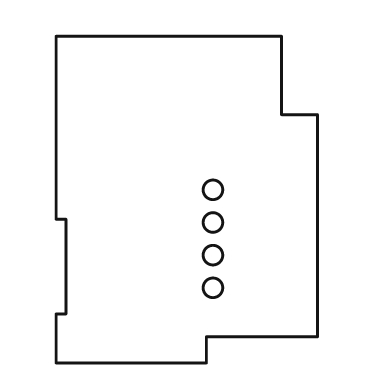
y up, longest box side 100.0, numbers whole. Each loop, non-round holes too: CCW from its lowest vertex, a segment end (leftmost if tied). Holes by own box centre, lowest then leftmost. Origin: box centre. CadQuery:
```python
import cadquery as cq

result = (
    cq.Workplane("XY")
    .moveTo(-40.0, -50.0)
    .lineTo(6.0, -50.0)
    .lineTo(6.0, -42.0)
    .lineTo(40.0, -42.0)
    .lineTo(40.0, 26.0)
    .lineTo(29.0, 26.0)
    .lineTo(29.0, 50.0)
    .lineTo(-40.0, 50.0)
    .lineTo(-40.0, -6.0)
    .lineTo(-37.0, -6.0)
    .lineTo(-37.0, -35.0)
    .lineTo(-40.0, -35.0)
    .close()
    .moveTo(8.0, -27.0)
    .circle(3.0)
    .moveTo(8.0, -17.0)
    .circle(3.0)
    .moveTo(8.0, -7.0)
    .circle(3.0)
    .moveTo(8.0, 3.0)
    .circle(3.0)
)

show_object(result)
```